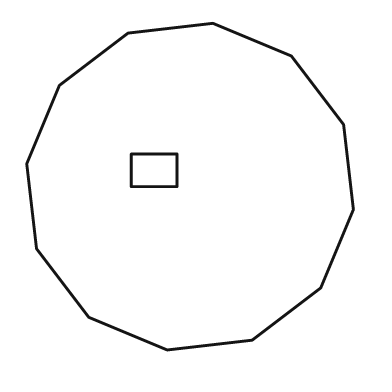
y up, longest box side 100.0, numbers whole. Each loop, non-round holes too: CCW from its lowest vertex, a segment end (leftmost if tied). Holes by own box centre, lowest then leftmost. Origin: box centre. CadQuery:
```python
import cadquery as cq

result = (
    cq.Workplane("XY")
    .moveTo(-7.0, -50.0)
    .lineTo(19.0, -47.0)
    .lineTo(40.0, -31.0)
    .lineTo(50.0, -7.0)
    .lineTo(47.0, 19.0)
    .lineTo(31.0, 40.0)
    .lineTo(7.0, 50.0)
    .lineTo(-19.0, 47.0)
    .lineTo(-40.0, 31.0)
    .lineTo(-50.0, 7.0)
    .lineTo(-47.0, -19.0)
    .lineTo(-31.0, -40.0)
    .close()
    .moveTo(-18.0, 0.0)
    .lineTo(-4.0, 0.0)
    .lineTo(-4.0, 10.0)
    .lineTo(-18.0, 10.0)
    .close()
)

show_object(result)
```